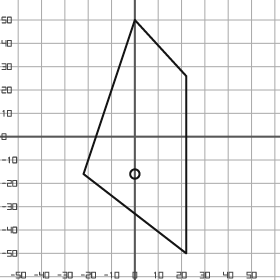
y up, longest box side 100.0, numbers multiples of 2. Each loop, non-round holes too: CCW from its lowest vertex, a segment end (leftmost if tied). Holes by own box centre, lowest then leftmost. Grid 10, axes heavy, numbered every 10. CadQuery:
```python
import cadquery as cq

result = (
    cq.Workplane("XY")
    .moveTo(22.0, -50.0)
    .lineTo(22.0, 26.0)
    .lineTo(0.0, 50.0)
    .lineTo(-22.0, -16.0)
    .close()
    .moveTo(0.0, -16.0)
    .circle(2.0)
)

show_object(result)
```